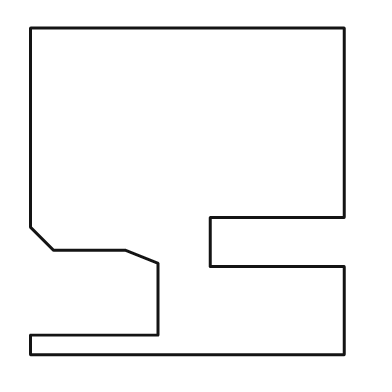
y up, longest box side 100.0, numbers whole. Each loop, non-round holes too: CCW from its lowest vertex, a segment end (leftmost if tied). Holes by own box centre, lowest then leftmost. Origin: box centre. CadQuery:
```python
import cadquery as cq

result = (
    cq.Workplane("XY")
    .moveTo(-48.0, -50.0)
    .lineTo(48.0, -50.0)
    .lineTo(48.0, -23.0)
    .lineTo(7.0, -23.0)
    .lineTo(7.0, -8.0)
    .lineTo(48.0, -8.0)
    .lineTo(48.0, 50.0)
    .lineTo(-48.0, 50.0)
    .lineTo(-48.0, -11.0)
    .lineTo(-41.0, -18.0)
    .lineTo(-19.0, -18.0)
    .lineTo(-9.0, -22.0)
    .lineTo(-9.0, -44.0)
    .lineTo(-48.0, -44.0)
    .close()
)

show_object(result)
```